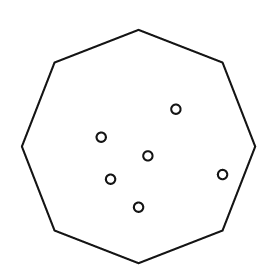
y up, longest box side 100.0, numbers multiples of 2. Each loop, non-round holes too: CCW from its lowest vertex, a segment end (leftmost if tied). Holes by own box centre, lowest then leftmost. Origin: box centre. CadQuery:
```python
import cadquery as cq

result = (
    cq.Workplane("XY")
    .moveTo(0.0, -50.0)
    .lineTo(36.0, -36.0)
    .lineTo(50.0, 0.0)
    .lineTo(36.0, 36.0)
    .lineTo(0.0, 50.0)
    .lineTo(-36.0, 36.0)
    .lineTo(-50.0, 0.0)
    .lineTo(-36.0, -36.0)
    .close()
    .moveTo(0.0, -26.0)
    .circle(2.0)
    .moveTo(-12.0, -14.0)
    .circle(2.0)
    .moveTo(36.0, -12.0)
    .circle(2.0)
    .moveTo(4.0, -4.0)
    .circle(2.0)
    .moveTo(-16.0, 4.0)
    .circle(2.0)
    .moveTo(16.0, 16.0)
    .circle(2.0)
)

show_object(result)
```